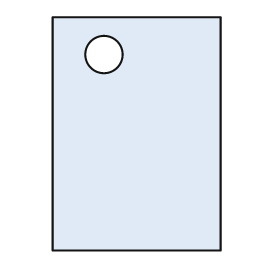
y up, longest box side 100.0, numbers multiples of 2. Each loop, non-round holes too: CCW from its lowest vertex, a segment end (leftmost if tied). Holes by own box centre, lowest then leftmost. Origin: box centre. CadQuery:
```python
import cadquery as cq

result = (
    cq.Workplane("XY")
    .moveTo(-36.0, -50.0)
    .lineTo(36.0, -50.0)
    .lineTo(36.0, 50.0)
    .lineTo(-36.0, 50.0)
    .close()
    .moveTo(-14.0, 34.0)
    .circle(8.0)
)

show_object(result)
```